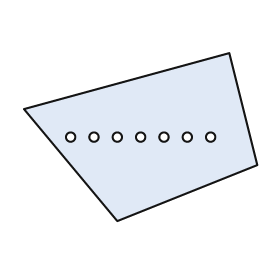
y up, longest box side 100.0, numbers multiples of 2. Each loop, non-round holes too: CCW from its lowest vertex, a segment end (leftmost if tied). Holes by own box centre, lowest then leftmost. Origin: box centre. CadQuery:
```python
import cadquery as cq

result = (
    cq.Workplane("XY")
    .moveTo(-10.0, -36.0)
    .lineTo(50.0, -12.0)
    .lineTo(38.0, 36.0)
    .lineTo(-50.0, 12.0)
    .close()
    .moveTo(-30.0, 0.0)
    .circle(2.0)
    .moveTo(-20.0, 0.0)
    .circle(2.0)
    .moveTo(-10.0, 0.0)
    .circle(2.0)
    .moveTo(0.0, 0.0)
    .circle(2.0)
    .moveTo(10.0, 0.0)
    .circle(2.0)
    .moveTo(20.0, 0.0)
    .circle(2.0)
    .moveTo(30.0, 0.0)
    .circle(2.0)
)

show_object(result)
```